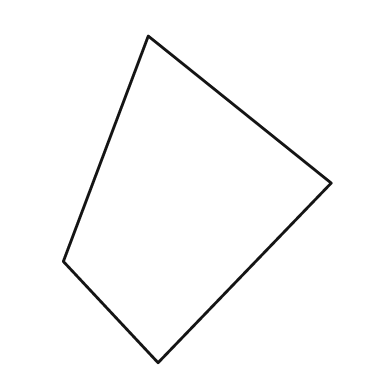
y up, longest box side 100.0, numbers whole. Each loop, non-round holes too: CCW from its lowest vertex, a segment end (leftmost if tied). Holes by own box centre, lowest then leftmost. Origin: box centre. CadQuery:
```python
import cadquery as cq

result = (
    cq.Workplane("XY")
    .moveTo(-12.0, -50.0)
    .lineTo(41.0, 5.0)
    .lineTo(-15.0, 50.0)
    .lineTo(-41.0, -19.0)
    .close()
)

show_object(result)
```